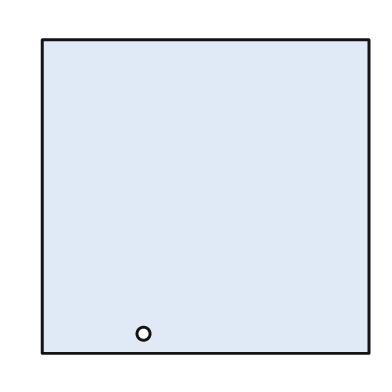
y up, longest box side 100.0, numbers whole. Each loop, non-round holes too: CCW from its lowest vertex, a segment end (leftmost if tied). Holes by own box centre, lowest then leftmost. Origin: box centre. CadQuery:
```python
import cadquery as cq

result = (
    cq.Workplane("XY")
    .moveTo(-50.0, -48.0)
    .lineTo(50.0, -48.0)
    .lineTo(50.0, 48.0)
    .lineTo(-50.0, 48.0)
    .close()
    .moveTo(-19.0, -42.0)
    .circle(2.0)
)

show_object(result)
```